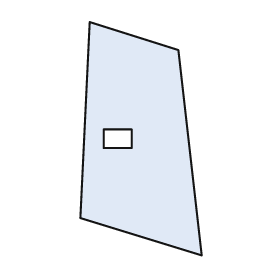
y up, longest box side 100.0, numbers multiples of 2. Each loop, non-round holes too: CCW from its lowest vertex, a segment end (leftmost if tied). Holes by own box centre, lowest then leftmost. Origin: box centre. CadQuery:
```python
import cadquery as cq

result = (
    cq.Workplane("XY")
    .moveTo(26.0, -50.0)
    .lineTo(16.0, 38.0)
    .lineTo(-22.0, 50.0)
    .lineTo(-26.0, -34.0)
    .close()
    .moveTo(-16.0, -4.0)
    .lineTo(-4.0, -4.0)
    .lineTo(-4.0, 4.0)
    .lineTo(-16.0, 4.0)
    .close()
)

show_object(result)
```